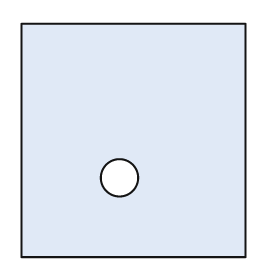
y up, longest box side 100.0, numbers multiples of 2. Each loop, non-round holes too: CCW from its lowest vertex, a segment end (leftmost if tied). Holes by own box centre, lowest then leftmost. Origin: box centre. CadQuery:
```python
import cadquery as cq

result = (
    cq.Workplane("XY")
    .moveTo(-48.0, -50.0)
    .lineTo(48.0, -50.0)
    .lineTo(48.0, 50.0)
    .lineTo(-48.0, 50.0)
    .close()
    .moveTo(-6.0, -16.0)
    .circle(8.0)
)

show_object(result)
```